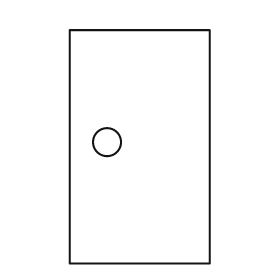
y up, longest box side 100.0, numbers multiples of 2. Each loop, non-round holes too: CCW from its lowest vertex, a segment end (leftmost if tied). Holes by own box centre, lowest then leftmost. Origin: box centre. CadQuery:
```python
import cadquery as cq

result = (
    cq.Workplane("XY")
    .moveTo(-30.0, -50.0)
    .lineTo(30.0, -50.0)
    .lineTo(30.0, 50.0)
    .lineTo(-30.0, 50.0)
    .close()
    .moveTo(-14.0, 2.0)
    .circle(6.0)
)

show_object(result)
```